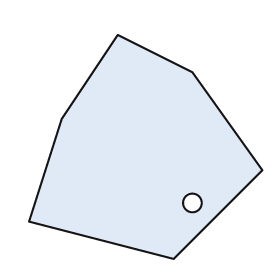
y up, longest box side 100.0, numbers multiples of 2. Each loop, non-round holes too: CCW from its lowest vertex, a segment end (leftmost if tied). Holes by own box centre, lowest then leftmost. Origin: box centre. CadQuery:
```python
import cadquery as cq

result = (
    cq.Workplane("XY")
    .moveTo(12.0, -48.0)
    .lineTo(50.0, -10.0)
    .lineTo(20.0, 32.0)
    .lineTo(-12.0, 48.0)
    .lineTo(-36.0, 12.0)
    .lineTo(-50.0, -32.0)
    .close()
    .moveTo(20.0, -24.0)
    .circle(4.0)
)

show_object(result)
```